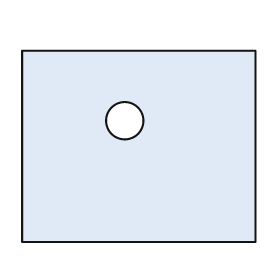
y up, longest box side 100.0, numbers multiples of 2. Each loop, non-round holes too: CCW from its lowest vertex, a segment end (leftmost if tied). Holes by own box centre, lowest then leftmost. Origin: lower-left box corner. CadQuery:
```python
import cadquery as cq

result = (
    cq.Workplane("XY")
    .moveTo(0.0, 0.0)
    .lineTo(100.0, 0.0)
    .lineTo(100.0, 82.0)
    .lineTo(0.0, 82.0)
    .close()
    .moveTo(44.0, 52.0)
    .circle(8.0)
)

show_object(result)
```